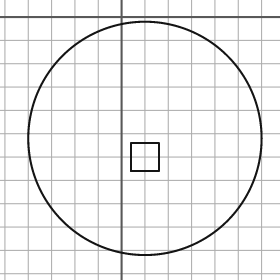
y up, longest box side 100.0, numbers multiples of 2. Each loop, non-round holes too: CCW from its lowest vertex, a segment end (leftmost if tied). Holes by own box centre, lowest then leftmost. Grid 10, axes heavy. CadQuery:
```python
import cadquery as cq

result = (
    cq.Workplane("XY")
    .moveTo(10.0, -52.0)
    .circle(50.0)
    .moveTo(4.0, -66.0)
    .lineTo(16.0, -66.0)
    .lineTo(16.0, -54.0)
    .lineTo(4.0, -54.0)
    .close()
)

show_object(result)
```